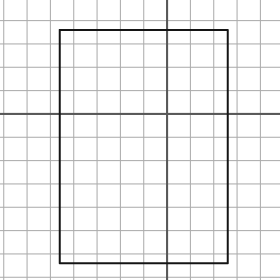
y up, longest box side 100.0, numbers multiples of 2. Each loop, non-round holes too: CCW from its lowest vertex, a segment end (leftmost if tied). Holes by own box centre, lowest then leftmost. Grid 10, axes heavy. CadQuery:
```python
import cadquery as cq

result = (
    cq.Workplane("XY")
    .moveTo(-46.0, -64.0)
    .lineTo(26.0, -64.0)
    .lineTo(26.0, 36.0)
    .lineTo(-46.0, 36.0)
    .close()
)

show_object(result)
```